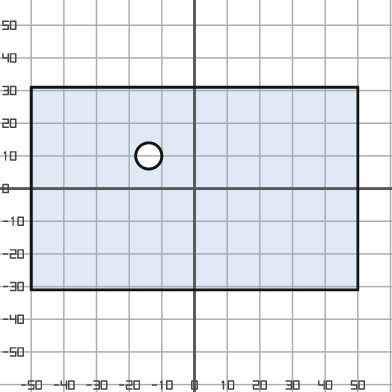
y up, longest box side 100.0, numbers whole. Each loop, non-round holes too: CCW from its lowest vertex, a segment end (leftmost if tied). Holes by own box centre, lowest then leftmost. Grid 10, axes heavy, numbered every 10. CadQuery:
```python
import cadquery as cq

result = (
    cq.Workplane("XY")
    .moveTo(-50.0, -31.0)
    .lineTo(50.0, -31.0)
    .lineTo(50.0, 31.0)
    .lineTo(-50.0, 31.0)
    .close()
    .moveTo(-14.0, 10.0)
    .circle(4.0)
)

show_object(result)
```